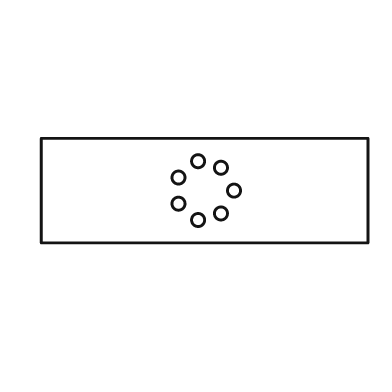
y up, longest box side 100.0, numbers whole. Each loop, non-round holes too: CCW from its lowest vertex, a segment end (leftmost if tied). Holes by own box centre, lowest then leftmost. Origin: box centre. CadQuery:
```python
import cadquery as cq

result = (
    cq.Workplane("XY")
    .moveTo(-50.0, -16.0)
    .lineTo(50.0, -16.0)
    .lineTo(50.0, 16.0)
    .lineTo(-50.0, 16.0)
    .close()
    .moveTo(-2.0, -9.0)
    .circle(2.0)
    .moveTo(5.0, -7.0)
    .circle(2.0)
    .moveTo(-8.0, -4.0)
    .circle(2.0)
    .moveTo(9.0, 0.0)
    .circle(2.0)
    .moveTo(-8.0, 4.0)
    .circle(2.0)
    .moveTo(5.0, 7.0)
    .circle(2.0)
    .moveTo(-2.0, 9.0)
    .circle(2.0)
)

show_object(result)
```